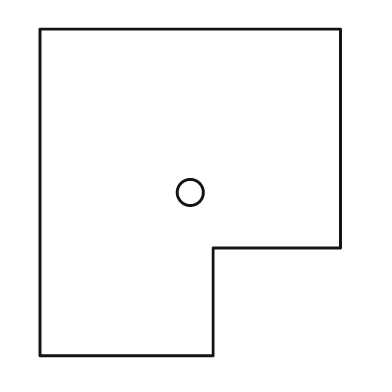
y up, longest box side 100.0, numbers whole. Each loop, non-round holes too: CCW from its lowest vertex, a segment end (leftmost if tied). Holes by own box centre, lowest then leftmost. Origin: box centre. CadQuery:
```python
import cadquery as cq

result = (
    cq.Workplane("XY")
    .moveTo(-46.0, -50.0)
    .lineTo(7.0, -50.0)
    .lineTo(7.0, -17.0)
    .lineTo(46.0, -17.0)
    .lineTo(46.0, 50.0)
    .lineTo(-46.0, 50.0)
    .close()
    .moveTo(0.0, 0.0)
    .circle(4.0)
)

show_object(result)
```